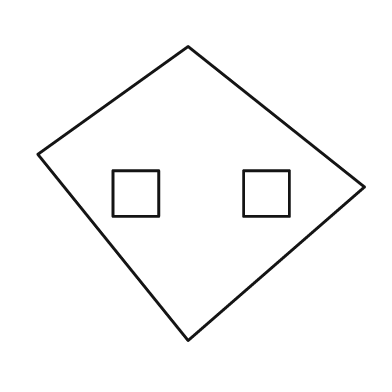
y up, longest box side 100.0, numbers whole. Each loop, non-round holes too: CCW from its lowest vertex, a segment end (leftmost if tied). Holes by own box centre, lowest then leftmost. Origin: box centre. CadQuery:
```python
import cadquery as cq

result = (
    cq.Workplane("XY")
    .moveTo(-4.0, -45.0)
    .lineTo(50.0, 2.0)
    .lineTo(-4.0, 45.0)
    .lineTo(-50.0, 12.0)
    .close()
    .moveTo(-27.0, -7.0)
    .lineTo(-13.0, -7.0)
    .lineTo(-13.0, 7.0)
    .lineTo(-27.0, 7.0)
    .close()
    .moveTo(13.0, -7.0)
    .lineTo(27.0, -7.0)
    .lineTo(27.0, 7.0)
    .lineTo(13.0, 7.0)
    .close()
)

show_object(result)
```